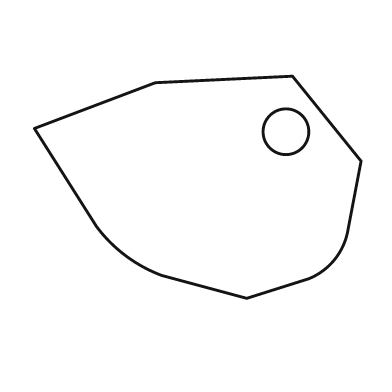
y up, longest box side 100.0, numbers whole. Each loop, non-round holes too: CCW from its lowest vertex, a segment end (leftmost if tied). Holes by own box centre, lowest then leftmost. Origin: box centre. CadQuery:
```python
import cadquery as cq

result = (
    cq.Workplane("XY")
    .moveTo(15.0, -34.0)
    .lineTo(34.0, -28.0)
    .threePointArc((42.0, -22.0), (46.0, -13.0))
    .lineTo(50.0, 8.0)
    .lineTo(29.0, 34.0)
    .lineTo(-13.0, 32.0)
    .lineTo(-50.0, 18.0)
    .lineTo(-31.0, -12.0)
    .threePointArc((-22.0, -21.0), (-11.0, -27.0))
    .close()
    .moveTo(27.0, 17.0)
    .circle(7.0)
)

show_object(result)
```